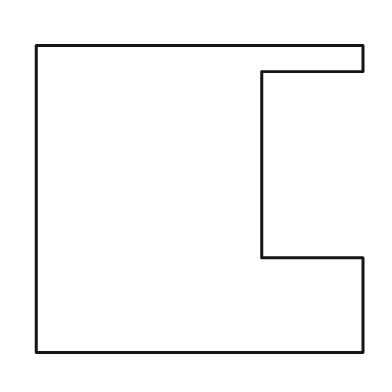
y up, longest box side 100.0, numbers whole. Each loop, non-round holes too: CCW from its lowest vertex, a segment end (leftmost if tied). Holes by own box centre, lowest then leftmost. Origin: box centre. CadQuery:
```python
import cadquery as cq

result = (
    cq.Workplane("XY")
    .moveTo(-50.0, -47.0)
    .lineTo(50.0, -47.0)
    .lineTo(50.0, -18.0)
    .lineTo(19.0, -18.0)
    .lineTo(19.0, 39.0)
    .lineTo(50.0, 39.0)
    .lineTo(50.0, 47.0)
    .lineTo(-50.0, 47.0)
    .close()
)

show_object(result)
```